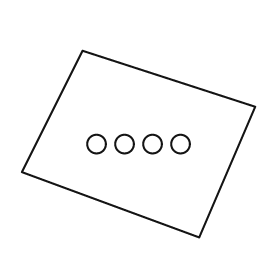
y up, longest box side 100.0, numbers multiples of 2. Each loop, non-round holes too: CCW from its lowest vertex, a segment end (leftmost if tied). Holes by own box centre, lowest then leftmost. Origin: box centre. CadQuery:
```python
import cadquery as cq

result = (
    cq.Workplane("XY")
    .moveTo(26.0, -40.0)
    .lineTo(50.0, 16.0)
    .lineTo(-24.0, 40.0)
    .lineTo(-50.0, -12.0)
    .close()
    .moveTo(-18.0, 0.0)
    .circle(4.0)
    .moveTo(-6.0, 0.0)
    .circle(4.0)
    .moveTo(6.0, 0.0)
    .circle(4.0)
    .moveTo(18.0, 0.0)
    .circle(4.0)
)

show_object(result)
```